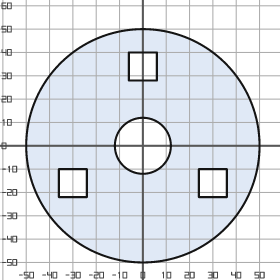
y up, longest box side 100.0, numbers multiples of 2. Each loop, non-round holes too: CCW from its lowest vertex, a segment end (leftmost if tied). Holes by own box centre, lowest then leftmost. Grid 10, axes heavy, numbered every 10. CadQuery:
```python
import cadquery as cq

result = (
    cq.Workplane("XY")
    .moveTo(0.0, 0.0)
    .circle(50.0)
    .moveTo(-36.0, -22.0)
    .lineTo(-24.0, -22.0)
    .lineTo(-24.0, -10.0)
    .lineTo(-36.0, -10.0)
    .close()
    .moveTo(24.0, -22.0)
    .lineTo(36.0, -22.0)
    .lineTo(36.0, -10.0)
    .lineTo(24.0, -10.0)
    .close()
    .moveTo(0.0, 0.0)
    .circle(12.0)
    .moveTo(-6.0, 28.0)
    .lineTo(6.0, 28.0)
    .lineTo(6.0, 40.0)
    .lineTo(-6.0, 40.0)
    .close()
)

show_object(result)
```